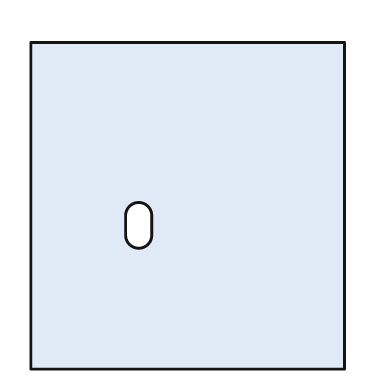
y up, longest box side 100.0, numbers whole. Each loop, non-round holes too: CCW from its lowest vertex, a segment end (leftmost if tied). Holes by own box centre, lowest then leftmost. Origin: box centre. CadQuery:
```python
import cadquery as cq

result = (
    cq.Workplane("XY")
    .moveTo(-48.0, -50.0)
    .lineTo(48.0, -50.0)
    .lineTo(48.0, 50.0)
    .lineTo(-48.0, 50.0)
    .close()
    .moveTo(-19.0, -9.0)
    .threePointArc((-15.0, -13.0), (-11.0, -9.0))
    .lineTo(-11.0, -3.0)
    .threePointArc((-15.0, 1.0), (-19.0, -3.0))
    .close()
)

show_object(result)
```